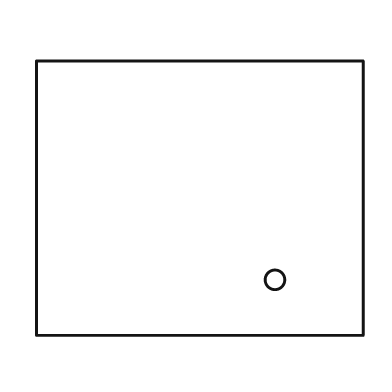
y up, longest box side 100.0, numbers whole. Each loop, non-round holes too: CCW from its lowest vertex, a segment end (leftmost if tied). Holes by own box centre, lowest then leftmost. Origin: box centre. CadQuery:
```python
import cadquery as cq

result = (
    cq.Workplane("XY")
    .moveTo(-50.0, -42.0)
    .lineTo(50.0, -42.0)
    .lineTo(50.0, 42.0)
    .lineTo(-50.0, 42.0)
    .close()
    .moveTo(23.0, -25.0)
    .circle(3.0)
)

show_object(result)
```